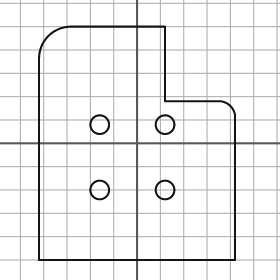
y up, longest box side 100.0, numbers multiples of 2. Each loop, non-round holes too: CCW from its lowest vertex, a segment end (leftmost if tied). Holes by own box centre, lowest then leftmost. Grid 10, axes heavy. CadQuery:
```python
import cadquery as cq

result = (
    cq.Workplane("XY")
    .moveTo(-42.0, -50.0)
    .lineTo(42.0, -50.0)
    .lineTo(42.0, 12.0)
    .threePointArc((40.0, 16.0), (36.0, 18.0))
    .lineTo(12.0, 18.0)
    .lineTo(12.0, 50.0)
    .lineTo(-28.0, 50.0)
    .threePointArc((-38.0, 46.0), (-42.0, 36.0))
    .close()
    .moveTo(-16.0, -20.0)
    .circle(4.0)
    .moveTo(12.0, -20.0)
    .circle(4.0)
    .moveTo(-16.0, 8.0)
    .circle(4.0)
    .moveTo(12.0, 8.0)
    .circle(4.0)
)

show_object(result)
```